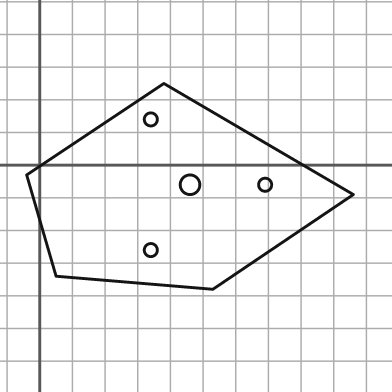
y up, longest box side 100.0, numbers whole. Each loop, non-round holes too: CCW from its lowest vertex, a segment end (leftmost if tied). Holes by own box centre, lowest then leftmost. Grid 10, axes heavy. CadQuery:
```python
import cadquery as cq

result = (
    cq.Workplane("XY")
    .moveTo(53.0, -38.0)
    .lineTo(96.0, -9.0)
    .lineTo(38.0, 25.0)
    .lineTo(-4.0, -3.0)
    .lineTo(5.0, -34.0)
    .close()
    .moveTo(34.0, -26.0)
    .circle(2.0)
    .moveTo(46.0, -6.0)
    .circle(3.0)
    .moveTo(69.0, -6.0)
    .circle(2.0)
    .moveTo(34.0, 14.0)
    .circle(2.0)
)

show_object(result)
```